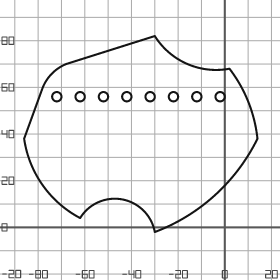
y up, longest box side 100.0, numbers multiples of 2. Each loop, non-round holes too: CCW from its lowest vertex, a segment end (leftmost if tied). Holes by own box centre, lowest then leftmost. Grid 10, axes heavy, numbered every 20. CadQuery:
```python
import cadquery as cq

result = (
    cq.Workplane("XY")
    .moveTo(-30.0, -2.0)
    .threePointArc((-4.0, 14.0), (14.0, 38.0))
    .threePointArc((10.0, 54.0), (2.0, 68.0))
    .threePointArc((-16.0, 70.0), (-30.0, 82.0))
    .lineTo(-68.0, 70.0)
    .threePointArc((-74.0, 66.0), (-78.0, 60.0))
    .lineTo(-86.0, 38.0)
    .threePointArc((-78.0, 18.0), (-62.0, 4.0))
    .threePointArc((-44.0, 12.0), (-30.0, -2.0))
    .close()
    .moveTo(-72.0, 56.0)
    .circle(2.0)
    .moveTo(-62.0, 56.0)
    .circle(2.0)
    .moveTo(-52.0, 56.0)
    .circle(2.0)
    .moveTo(-42.0, 56.0)
    .circle(2.0)
    .moveTo(-32.0, 56.0)
    .circle(2.0)
    .moveTo(-22.0, 56.0)
    .circle(2.0)
    .moveTo(-12.0, 56.0)
    .circle(2.0)
    .moveTo(-2.0, 56.0)
    .circle(2.0)
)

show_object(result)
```